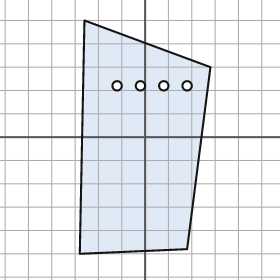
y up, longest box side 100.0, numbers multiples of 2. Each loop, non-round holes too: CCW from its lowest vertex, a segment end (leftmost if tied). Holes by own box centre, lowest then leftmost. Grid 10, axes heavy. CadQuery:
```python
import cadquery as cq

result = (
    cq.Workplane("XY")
    .moveTo(-28.0, -50.0)
    .lineTo(18.0, -48.0)
    .lineTo(28.0, 30.0)
    .lineTo(-26.0, 50.0)
    .close()
    .moveTo(-12.0, 22.0)
    .circle(2.0)
    .moveTo(-2.0, 22.0)
    .circle(2.0)
    .moveTo(8.0, 22.0)
    .circle(2.0)
    .moveTo(18.0, 22.0)
    .circle(2.0)
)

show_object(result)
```